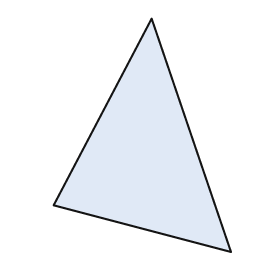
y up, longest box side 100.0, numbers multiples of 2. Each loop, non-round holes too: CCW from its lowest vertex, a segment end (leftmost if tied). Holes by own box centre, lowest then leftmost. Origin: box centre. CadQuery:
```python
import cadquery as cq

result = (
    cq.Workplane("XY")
    .moveTo(38.0, -50.0)
    .lineTo(4.0, 50.0)
    .lineTo(-38.0, -30.0)
    .close()
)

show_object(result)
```